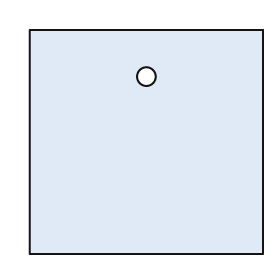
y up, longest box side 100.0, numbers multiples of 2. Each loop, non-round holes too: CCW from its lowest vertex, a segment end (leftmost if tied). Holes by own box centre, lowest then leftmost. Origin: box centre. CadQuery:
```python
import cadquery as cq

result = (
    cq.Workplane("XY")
    .moveTo(-50.0, -48.0)
    .lineTo(50.0, -48.0)
    .lineTo(50.0, 48.0)
    .lineTo(-50.0, 48.0)
    .close()
    .moveTo(0.0, 28.0)
    .circle(4.0)
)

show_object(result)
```